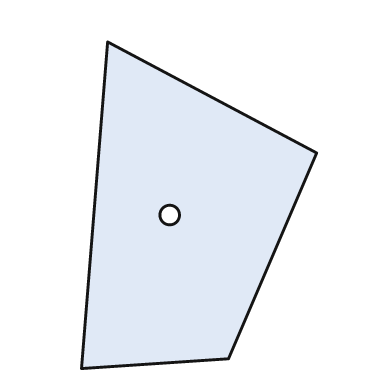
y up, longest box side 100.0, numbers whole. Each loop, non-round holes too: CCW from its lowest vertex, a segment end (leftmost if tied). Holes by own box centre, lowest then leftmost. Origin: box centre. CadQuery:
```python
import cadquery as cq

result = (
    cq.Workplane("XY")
    .moveTo(-36.0, -50.0)
    .lineTo(9.0, -47.0)
    .lineTo(36.0, 16.0)
    .lineTo(-28.0, 50.0)
    .close()
    .moveTo(-9.0, -3.0)
    .circle(3.0)
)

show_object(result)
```